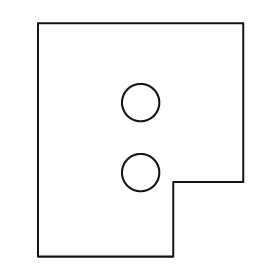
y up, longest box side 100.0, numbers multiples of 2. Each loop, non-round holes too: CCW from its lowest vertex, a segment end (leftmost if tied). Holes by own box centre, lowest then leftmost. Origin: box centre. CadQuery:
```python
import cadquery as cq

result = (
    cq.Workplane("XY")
    .moveTo(-44.0, -50.0)
    .lineTo(14.0, -50.0)
    .lineTo(14.0, -18.0)
    .lineTo(44.0, -18.0)
    .lineTo(44.0, 50.0)
    .lineTo(-44.0, 50.0)
    .close()
    .moveTo(0.0, -14.0)
    .circle(8.0)
    .moveTo(0.0, 16.0)
    .circle(8.0)
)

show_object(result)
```